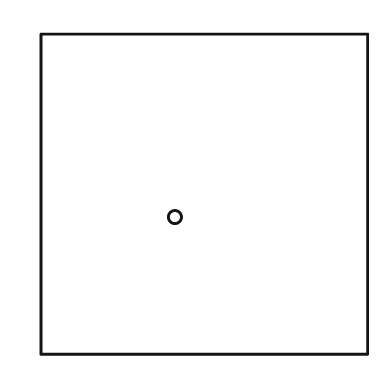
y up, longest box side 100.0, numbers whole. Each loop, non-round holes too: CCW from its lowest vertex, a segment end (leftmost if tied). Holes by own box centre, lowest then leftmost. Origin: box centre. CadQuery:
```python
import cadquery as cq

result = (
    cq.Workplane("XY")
    .moveTo(-50.0, -49.0)
    .lineTo(50.0, -49.0)
    .lineTo(50.0, 49.0)
    .lineTo(-50.0, 49.0)
    .close()
    .moveTo(-9.0, -7.0)
    .circle(2.0)
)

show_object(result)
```